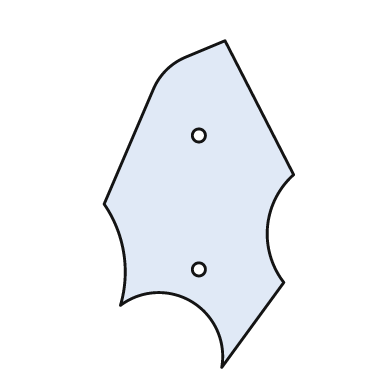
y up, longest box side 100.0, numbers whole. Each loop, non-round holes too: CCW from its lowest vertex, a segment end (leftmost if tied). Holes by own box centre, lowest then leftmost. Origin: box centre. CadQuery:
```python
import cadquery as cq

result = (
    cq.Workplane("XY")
    .moveTo(7.0, -50.0)
    .lineTo(26.0, -24.0)
    .threePointArc((21.0, -7.0), (29.0, 9.0))
    .lineTo(8.0, 50.0)
    .lineTo(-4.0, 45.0)
    .threePointArc((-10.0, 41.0), (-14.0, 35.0))
    .lineTo(-29.0, 0.0)
    .threePointArc((-23.0, -15.0), (-24.0, -31.0))
    .threePointArc((-2.0, -30.0), (7.0, -50.0))
    .close()
    .moveTo(0.0, -20.0)
    .circle(2.0)
    .moveTo(0.0, 21.0)
    .circle(2.0)
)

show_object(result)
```